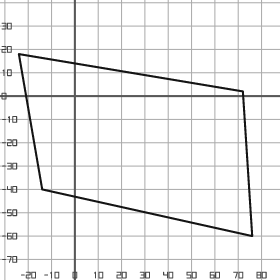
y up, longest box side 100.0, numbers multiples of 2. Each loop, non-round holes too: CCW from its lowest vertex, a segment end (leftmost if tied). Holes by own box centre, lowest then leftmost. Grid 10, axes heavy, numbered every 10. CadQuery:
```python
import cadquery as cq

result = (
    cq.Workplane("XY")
    .moveTo(76.0, -60.0)
    .lineTo(72.0, 2.0)
    .lineTo(-24.0, 18.0)
    .lineTo(-14.0, -40.0)
    .close()
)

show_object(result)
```